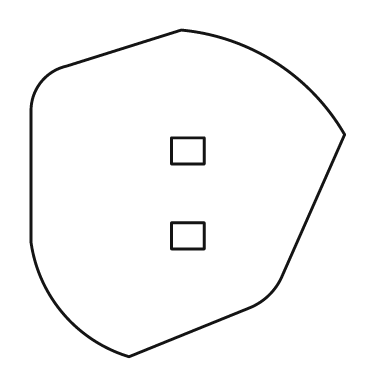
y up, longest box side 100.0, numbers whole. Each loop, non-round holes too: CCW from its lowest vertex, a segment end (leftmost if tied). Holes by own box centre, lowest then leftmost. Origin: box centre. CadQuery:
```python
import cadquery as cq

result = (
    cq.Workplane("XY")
    .moveTo(-18.0, -50.0)
    .lineTo(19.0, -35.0)
    .threePointArc((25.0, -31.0), (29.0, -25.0))
    .lineTo(48.0, 18.0)
    .threePointArc((27.0, 40.0), (-2.0, 50.0))
    .lineTo(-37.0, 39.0)
    .threePointArc((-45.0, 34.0), (-48.0, 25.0))
    .lineTo(-48.0, -15.0)
    .threePointArc((-38.0, -37.0), (-18.0, -50.0))
    .close()
    .moveTo(-5.0, -17.0)
    .lineTo(5.0, -17.0)
    .lineTo(5.0, -9.0)
    .lineTo(-5.0, -9.0)
    .close()
    .moveTo(-5.0, 9.0)
    .lineTo(5.0, 9.0)
    .lineTo(5.0, 17.0)
    .lineTo(-5.0, 17.0)
    .close()
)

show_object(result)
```